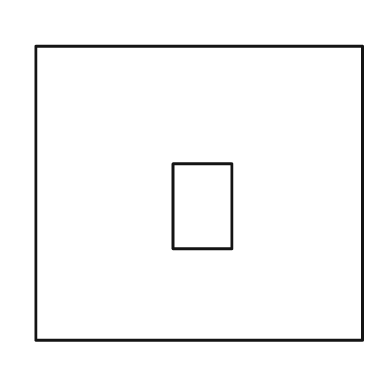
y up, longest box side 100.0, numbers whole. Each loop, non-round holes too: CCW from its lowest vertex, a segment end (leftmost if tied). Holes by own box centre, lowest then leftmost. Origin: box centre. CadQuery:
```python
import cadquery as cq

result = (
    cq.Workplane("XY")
    .moveTo(-50.0, -45.0)
    .lineTo(50.0, -45.0)
    .lineTo(50.0, 45.0)
    .lineTo(-50.0, 45.0)
    .close()
    .moveTo(-8.0, -17.0)
    .lineTo(10.0, -17.0)
    .lineTo(10.0, 9.0)
    .lineTo(-8.0, 9.0)
    .close()
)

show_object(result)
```